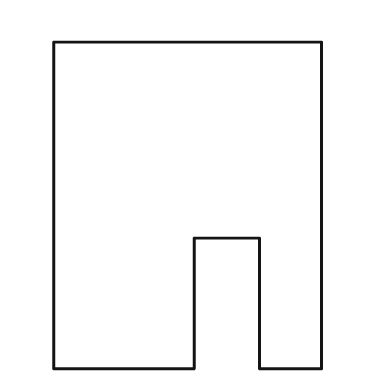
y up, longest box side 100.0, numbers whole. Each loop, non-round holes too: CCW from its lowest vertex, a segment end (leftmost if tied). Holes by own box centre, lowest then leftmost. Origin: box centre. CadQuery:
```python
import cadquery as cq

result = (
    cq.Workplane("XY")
    .moveTo(-41.0, -50.0)
    .lineTo(2.0, -50.0)
    .lineTo(2.0, -10.0)
    .lineTo(22.0, -10.0)
    .lineTo(22.0, -50.0)
    .lineTo(41.0, -50.0)
    .lineTo(41.0, 50.0)
    .lineTo(-41.0, 50.0)
    .close()
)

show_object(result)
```